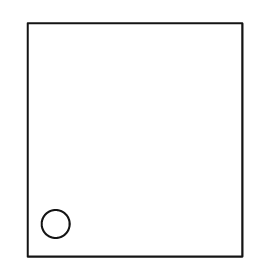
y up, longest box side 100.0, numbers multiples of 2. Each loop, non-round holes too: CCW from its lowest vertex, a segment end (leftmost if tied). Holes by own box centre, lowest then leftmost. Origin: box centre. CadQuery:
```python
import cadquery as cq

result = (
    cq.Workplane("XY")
    .moveTo(-46.0, -50.0)
    .lineTo(46.0, -50.0)
    .lineTo(46.0, 50.0)
    .lineTo(-46.0, 50.0)
    .close()
    .moveTo(-34.0, -36.0)
    .circle(6.0)
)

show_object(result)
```